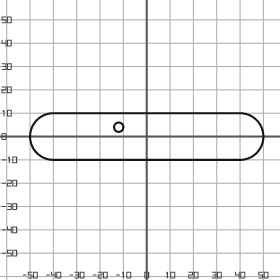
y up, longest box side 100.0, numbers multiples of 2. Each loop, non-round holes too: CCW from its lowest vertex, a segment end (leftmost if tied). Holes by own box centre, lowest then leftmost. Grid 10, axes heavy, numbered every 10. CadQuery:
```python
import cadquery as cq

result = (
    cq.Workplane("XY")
    .moveTo(-40.0, -10.0)
    .lineTo(40.0, -10.0)
    .threePointArc((50.0, 0.0), (40.0, 10.0))
    .lineTo(-40.0, 10.0)
    .threePointArc((-50.0, 0.0), (-40.0, -10.0))
    .close()
    .moveTo(-12.0, 4.0)
    .circle(2.0)
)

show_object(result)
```